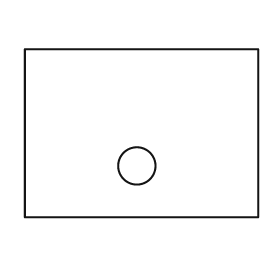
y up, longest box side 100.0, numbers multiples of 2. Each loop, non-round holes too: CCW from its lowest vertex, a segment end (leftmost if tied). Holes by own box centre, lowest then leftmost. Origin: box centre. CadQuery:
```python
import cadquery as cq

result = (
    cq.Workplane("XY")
    .moveTo(-50.0, -36.0)
    .lineTo(50.0, -36.0)
    .lineTo(50.0, 36.0)
    .lineTo(-50.0, 36.0)
    .close()
    .moveTo(-2.0, -14.0)
    .circle(8.0)
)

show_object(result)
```